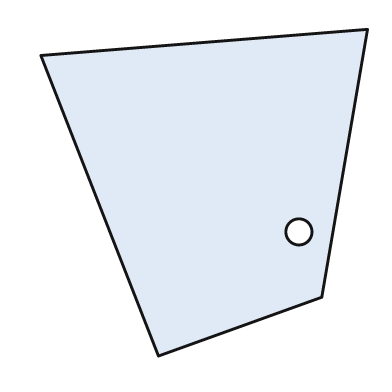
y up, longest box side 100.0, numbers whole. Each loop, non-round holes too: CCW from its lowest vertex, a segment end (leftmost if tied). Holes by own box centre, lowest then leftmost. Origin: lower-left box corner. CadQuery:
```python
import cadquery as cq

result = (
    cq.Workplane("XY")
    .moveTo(36.0, 0.0)
    .lineTo(86.0, 18.0)
    .lineTo(100.0, 100.0)
    .lineTo(0.0, 92.0)
    .close()
    .moveTo(79.0, 38.0)
    .circle(4.0)
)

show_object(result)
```